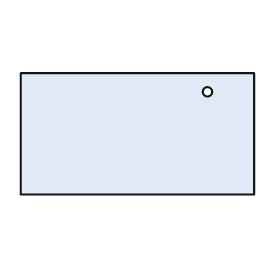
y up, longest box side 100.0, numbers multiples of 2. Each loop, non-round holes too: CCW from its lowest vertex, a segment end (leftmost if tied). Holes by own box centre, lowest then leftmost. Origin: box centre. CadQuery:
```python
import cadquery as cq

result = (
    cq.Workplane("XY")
    .moveTo(-50.0, -26.0)
    .lineTo(50.0, -26.0)
    .lineTo(50.0, 26.0)
    .lineTo(-50.0, 26.0)
    .close()
    .moveTo(30.0, 18.0)
    .circle(2.0)
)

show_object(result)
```